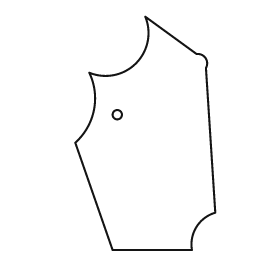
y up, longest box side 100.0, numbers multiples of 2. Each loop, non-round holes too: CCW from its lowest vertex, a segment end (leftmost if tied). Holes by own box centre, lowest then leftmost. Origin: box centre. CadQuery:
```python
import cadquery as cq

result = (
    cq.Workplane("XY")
    .moveTo(-14.0, -50.0)
    .lineTo(20.0, -50.0)
    .threePointArc((22.0, -40.0), (30.0, -34.0))
    .lineTo(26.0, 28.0)
    .threePointArc((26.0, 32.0), (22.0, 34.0))
    .lineTo(0.0, 50.0)
    .threePointArc((-4.0, 30.0), (-24.0, 26.0))
    .threePointArc((-22.0, 10.0), (-30.0, -4.0))
    .close()
    .moveTo(-12.0, 8.0)
    .circle(2.0)
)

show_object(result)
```